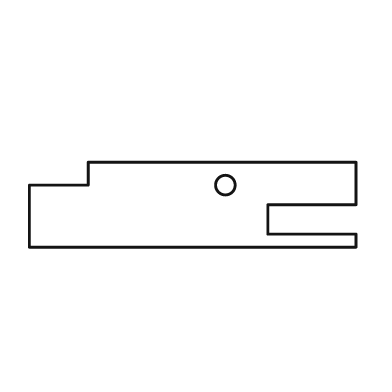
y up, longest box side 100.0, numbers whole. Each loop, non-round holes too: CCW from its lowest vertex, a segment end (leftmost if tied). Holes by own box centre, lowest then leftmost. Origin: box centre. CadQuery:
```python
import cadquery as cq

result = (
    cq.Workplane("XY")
    .moveTo(-50.0, -13.0)
    .lineTo(50.0, -13.0)
    .lineTo(50.0, -9.0)
    .lineTo(23.0, -9.0)
    .lineTo(23.0, 0.0)
    .lineTo(50.0, 0.0)
    .lineTo(50.0, 13.0)
    .lineTo(-32.0, 13.0)
    .lineTo(-32.0, 6.0)
    .lineTo(-50.0, 6.0)
    .close()
    .moveTo(10.0, 6.0)
    .circle(3.0)
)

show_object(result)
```